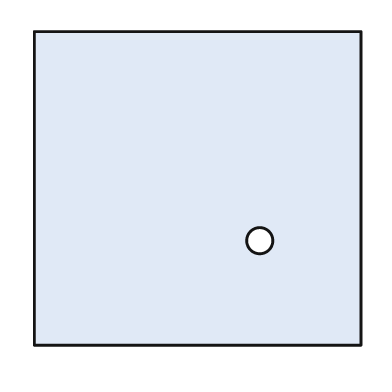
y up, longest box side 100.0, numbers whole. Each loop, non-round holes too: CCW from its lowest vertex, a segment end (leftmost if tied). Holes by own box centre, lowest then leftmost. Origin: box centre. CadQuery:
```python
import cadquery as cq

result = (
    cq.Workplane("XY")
    .moveTo(-50.0, -48.0)
    .lineTo(50.0, -48.0)
    .lineTo(50.0, 48.0)
    .lineTo(-50.0, 48.0)
    .close()
    .moveTo(19.0, -16.0)
    .circle(4.0)
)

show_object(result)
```